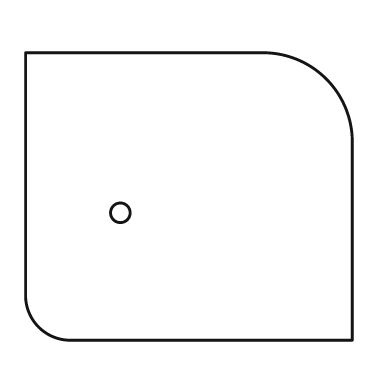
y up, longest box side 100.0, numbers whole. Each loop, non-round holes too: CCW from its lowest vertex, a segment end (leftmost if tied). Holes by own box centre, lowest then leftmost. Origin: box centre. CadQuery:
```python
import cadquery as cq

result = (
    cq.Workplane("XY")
    .moveTo(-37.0, -44.0)
    .lineTo(50.0, -44.0)
    .lineTo(50.0, 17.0)
    .threePointArc((42.0, 36.0), (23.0, 44.0))
    .lineTo(-50.0, 44.0)
    .lineTo(-50.0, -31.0)
    .threePointArc((-46.0, -40.0), (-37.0, -44.0))
    .close()
    .moveTo(-21.0, -5.0)
    .circle(3.0)
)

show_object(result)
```